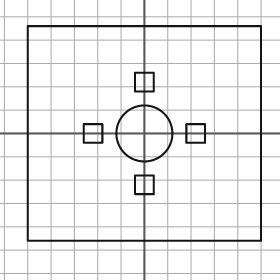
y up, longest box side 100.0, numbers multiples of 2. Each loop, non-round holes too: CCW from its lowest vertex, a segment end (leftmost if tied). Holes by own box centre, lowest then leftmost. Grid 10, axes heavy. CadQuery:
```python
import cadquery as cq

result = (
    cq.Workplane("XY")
    .moveTo(-50.0, -46.0)
    .lineTo(50.0, -46.0)
    .lineTo(50.0, 46.0)
    .lineTo(-50.0, 46.0)
    .close()
    .moveTo(-4.0, -26.0)
    .lineTo(4.0, -26.0)
    .lineTo(4.0, -18.0)
    .lineTo(-4.0, -18.0)
    .close()
    .moveTo(-26.0, -4.0)
    .lineTo(-18.0, -4.0)
    .lineTo(-18.0, 4.0)
    .lineTo(-26.0, 4.0)
    .close()
    .moveTo(0.0, 0.0)
    .circle(12.0)
    .moveTo(18.0, -4.0)
    .lineTo(26.0, -4.0)
    .lineTo(26.0, 4.0)
    .lineTo(18.0, 4.0)
    .close()
    .moveTo(-4.0, 18.0)
    .lineTo(4.0, 18.0)
    .lineTo(4.0, 26.0)
    .lineTo(-4.0, 26.0)
    .close()
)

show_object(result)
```